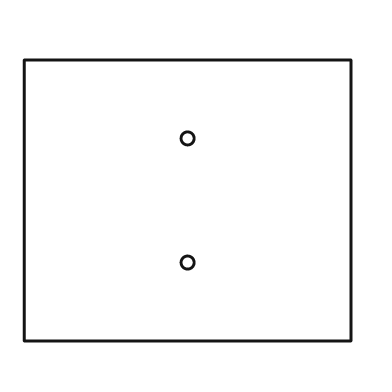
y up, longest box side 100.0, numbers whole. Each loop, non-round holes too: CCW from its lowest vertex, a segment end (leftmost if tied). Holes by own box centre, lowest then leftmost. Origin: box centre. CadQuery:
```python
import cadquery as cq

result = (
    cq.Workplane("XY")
    .moveTo(-50.0, -43.0)
    .lineTo(50.0, -43.0)
    .lineTo(50.0, 43.0)
    .lineTo(-50.0, 43.0)
    .close()
    .moveTo(0.0, -19.0)
    .circle(2.0)
    .moveTo(0.0, 19.0)
    .circle(2.0)
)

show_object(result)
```